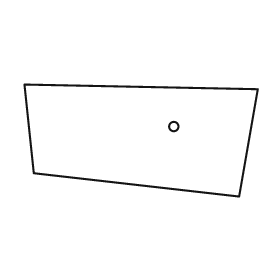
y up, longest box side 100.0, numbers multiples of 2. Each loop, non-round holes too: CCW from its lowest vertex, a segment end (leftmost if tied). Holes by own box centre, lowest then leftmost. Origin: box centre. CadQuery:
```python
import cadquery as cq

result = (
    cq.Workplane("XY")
    .moveTo(42.0, -24.0)
    .lineTo(50.0, 22.0)
    .lineTo(-50.0, 24.0)
    .lineTo(-46.0, -14.0)
    .close()
    .moveTo(14.0, 6.0)
    .circle(2.0)
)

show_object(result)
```